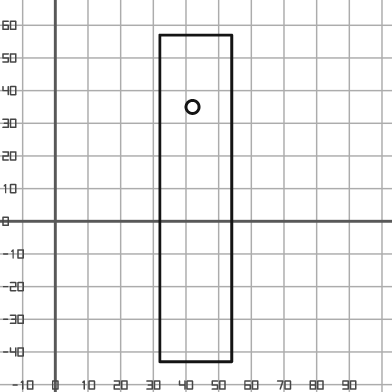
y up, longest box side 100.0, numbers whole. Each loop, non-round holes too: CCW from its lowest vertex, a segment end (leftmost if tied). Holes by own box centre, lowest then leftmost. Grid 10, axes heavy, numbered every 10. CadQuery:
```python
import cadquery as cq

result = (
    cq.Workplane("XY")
    .moveTo(32.0, -43.0)
    .lineTo(54.0, -43.0)
    .lineTo(54.0, 57.0)
    .lineTo(32.0, 57.0)
    .close()
    .moveTo(42.0, 35.0)
    .circle(2.0)
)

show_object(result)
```